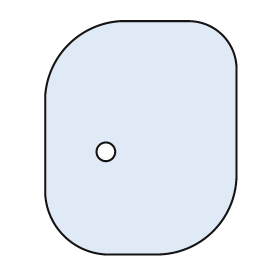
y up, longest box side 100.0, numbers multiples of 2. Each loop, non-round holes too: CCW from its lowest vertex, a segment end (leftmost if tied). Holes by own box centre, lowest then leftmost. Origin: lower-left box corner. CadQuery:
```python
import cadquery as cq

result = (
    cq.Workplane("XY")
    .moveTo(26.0, 0.0)
    .lineTo(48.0, 0.0)
    .threePointArc((72.0, 10.0), (82.0, 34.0))
    .lineTo(82.0, 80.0)
    .threePointArc((76.0, 94.0), (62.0, 100.0))
    .lineTo(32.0, 100.0)
    .threePointArc((10.0, 90.0), (0.0, 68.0))
    .lineTo(0.0, 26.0)
    .threePointArc((8.0, 8.0), (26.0, 0.0))
    .close()
    .moveTo(26.0, 44.0)
    .circle(4.0)
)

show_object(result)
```